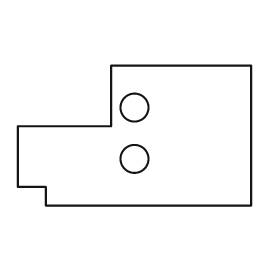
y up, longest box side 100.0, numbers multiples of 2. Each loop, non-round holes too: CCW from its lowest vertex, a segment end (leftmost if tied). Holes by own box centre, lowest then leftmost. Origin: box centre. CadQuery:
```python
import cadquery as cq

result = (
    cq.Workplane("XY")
    .moveTo(-38.0, -30.0)
    .lineTo(50.0, -30.0)
    .lineTo(50.0, 30.0)
    .lineTo(-10.0, 30.0)
    .lineTo(-10.0, 4.0)
    .lineTo(-50.0, 4.0)
    .lineTo(-50.0, -22.0)
    .lineTo(-38.0, -22.0)
    .close()
    .moveTo(0.0, -10.0)
    .circle(6.0)
    .moveTo(0.0, 12.0)
    .circle(6.0)
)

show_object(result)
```